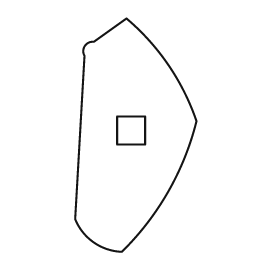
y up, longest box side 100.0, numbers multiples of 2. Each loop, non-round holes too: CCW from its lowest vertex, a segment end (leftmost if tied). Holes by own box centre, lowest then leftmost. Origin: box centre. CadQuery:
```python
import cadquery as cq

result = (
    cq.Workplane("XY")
    .moveTo(-6.0, -50.0)
    .threePointArc((14.0, -24.0), (26.0, 6.0))
    .threePointArc((14.0, 30.0), (-4.0, 50.0))
    .lineTo(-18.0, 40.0)
    .threePointArc((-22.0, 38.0), (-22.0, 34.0))
    .lineTo(-26.0, -36.0)
    .threePointArc((-18.0, -46.0), (-6.0, -50.0))
    .close()
    .moveTo(-8.0, -4.0)
    .lineTo(4.0, -4.0)
    .lineTo(4.0, 8.0)
    .lineTo(-8.0, 8.0)
    .close()
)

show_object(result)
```